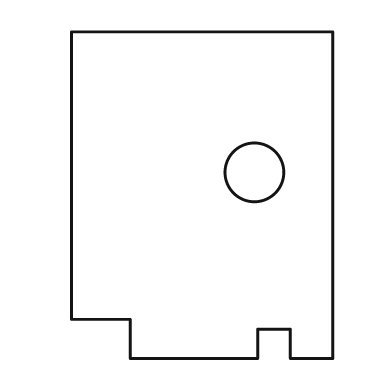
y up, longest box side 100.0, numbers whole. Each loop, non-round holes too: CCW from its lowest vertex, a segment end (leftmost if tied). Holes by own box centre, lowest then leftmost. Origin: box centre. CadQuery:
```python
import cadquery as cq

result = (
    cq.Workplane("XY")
    .moveTo(-22.0, -50.0)
    .lineTo(17.0, -50.0)
    .lineTo(17.0, -41.0)
    .lineTo(27.0, -41.0)
    .lineTo(27.0, -50.0)
    .lineTo(40.0, -50.0)
    .lineTo(40.0, 50.0)
    .lineTo(-40.0, 50.0)
    .lineTo(-40.0, -38.0)
    .lineTo(-22.0, -38.0)
    .close()
    .moveTo(16.0, 7.0)
    .circle(9.0)
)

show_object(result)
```